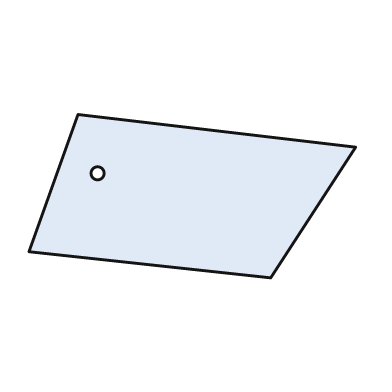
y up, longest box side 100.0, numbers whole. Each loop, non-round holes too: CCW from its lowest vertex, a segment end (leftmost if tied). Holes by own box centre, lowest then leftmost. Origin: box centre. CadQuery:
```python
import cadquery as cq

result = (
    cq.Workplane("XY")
    .moveTo(24.0, -25.0)
    .lineTo(50.0, 15.0)
    .lineTo(-35.0, 25.0)
    .lineTo(-50.0, -17.0)
    .close()
    .moveTo(-29.0, 7.0)
    .circle(2.0)
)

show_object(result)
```